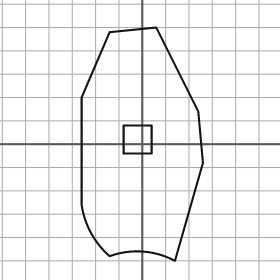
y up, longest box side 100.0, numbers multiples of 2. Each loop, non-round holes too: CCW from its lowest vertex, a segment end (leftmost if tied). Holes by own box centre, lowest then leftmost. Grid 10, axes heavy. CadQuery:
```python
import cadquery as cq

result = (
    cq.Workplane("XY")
    .moveTo(14.0, -50.0)
    .lineTo(26.0, -8.0)
    .lineTo(24.0, 14.0)
    .lineTo(6.0, 50.0)
    .lineTo(-14.0, 48.0)
    .lineTo(-26.0, 20.0)
    .lineTo(-26.0, -26.0)
    .threePointArc((-22.0, -38.0), (-14.0, -48.0))
    .threePointArc((0.0, -46.0), (14.0, -50.0))
    .close()
    .moveTo(-8.0, -4.0)
    .lineTo(4.0, -4.0)
    .lineTo(4.0, 8.0)
    .lineTo(-8.0, 8.0)
    .close()
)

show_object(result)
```